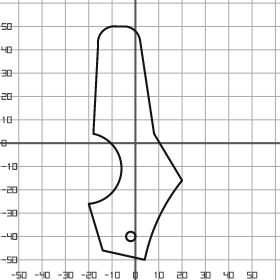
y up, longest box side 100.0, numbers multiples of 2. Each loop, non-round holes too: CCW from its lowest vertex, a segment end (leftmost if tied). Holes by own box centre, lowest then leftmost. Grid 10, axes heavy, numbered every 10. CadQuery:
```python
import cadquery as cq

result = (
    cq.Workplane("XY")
    .moveTo(4.0, -50.0)
    .threePointArc((10.0, -32.0), (20.0, -16.0))
    .lineTo(8.0, 4.0)
    .lineTo(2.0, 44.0)
    .threePointArc((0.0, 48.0), (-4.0, 50.0))
    .lineTo(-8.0, 50.0)
    .threePointArc((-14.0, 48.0), (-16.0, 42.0))
    .lineTo(-18.0, 4.0)
    .threePointArc((-6.0, -12.0), (-20.0, -26.0))
    .lineTo(-14.0, -46.0)
    .close()
    .moveTo(-2.0, -40.0)
    .circle(2.0)
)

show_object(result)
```